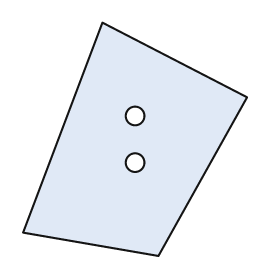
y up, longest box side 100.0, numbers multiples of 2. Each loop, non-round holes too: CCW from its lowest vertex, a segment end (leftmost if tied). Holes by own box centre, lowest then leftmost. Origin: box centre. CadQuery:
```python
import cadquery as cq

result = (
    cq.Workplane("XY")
    .moveTo(10.0, -50.0)
    .lineTo(48.0, 18.0)
    .lineTo(-14.0, 50.0)
    .lineTo(-48.0, -40.0)
    .close()
    .moveTo(0.0, -10.0)
    .circle(4.0)
    .moveTo(0.0, 10.0)
    .circle(4.0)
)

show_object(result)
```